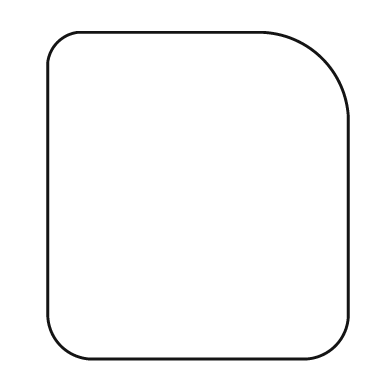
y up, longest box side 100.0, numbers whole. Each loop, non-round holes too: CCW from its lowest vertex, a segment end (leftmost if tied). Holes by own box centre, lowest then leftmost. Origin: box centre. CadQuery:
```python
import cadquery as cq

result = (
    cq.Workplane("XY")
    .moveTo(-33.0, -50.0)
    .lineTo(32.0, -50.0)
    .threePointArc((42.0, -46.0), (46.0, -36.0))
    .lineTo(46.0, 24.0)
    .threePointArc((38.0, 42.0), (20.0, 50.0))
    .lineTo(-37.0, 50.0)
    .threePointArc((-43.0, 47.0), (-46.0, 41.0))
    .lineTo(-46.0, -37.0)
    .threePointArc((-42.0, -46.0), (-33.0, -50.0))
    .close()
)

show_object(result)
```